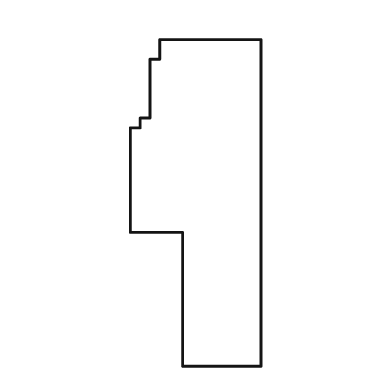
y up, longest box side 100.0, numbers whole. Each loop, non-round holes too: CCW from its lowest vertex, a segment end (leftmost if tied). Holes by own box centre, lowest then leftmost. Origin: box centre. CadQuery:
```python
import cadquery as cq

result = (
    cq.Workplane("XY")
    .moveTo(-4.0, -50.0)
    .lineTo(20.0, -50.0)
    .lineTo(20.0, 50.0)
    .lineTo(-11.0, 50.0)
    .lineTo(-11.0, 44.0)
    .lineTo(-14.0, 44.0)
    .lineTo(-14.0, 26.0)
    .lineTo(-17.0, 26.0)
    .lineTo(-17.0, 23.0)
    .lineTo(-20.0, 23.0)
    .lineTo(-20.0, -9.0)
    .lineTo(-4.0, -9.0)
    .close()
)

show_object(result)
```